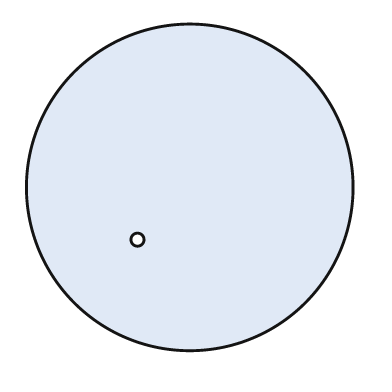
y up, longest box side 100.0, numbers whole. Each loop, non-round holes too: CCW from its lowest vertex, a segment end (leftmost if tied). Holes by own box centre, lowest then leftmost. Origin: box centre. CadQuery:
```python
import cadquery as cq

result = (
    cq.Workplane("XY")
    .moveTo(0.0, 0.0)
    .circle(50.0)
    .moveTo(-16.0, -16.0)
    .circle(2.0)
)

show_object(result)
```